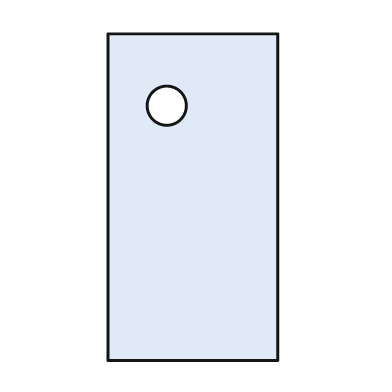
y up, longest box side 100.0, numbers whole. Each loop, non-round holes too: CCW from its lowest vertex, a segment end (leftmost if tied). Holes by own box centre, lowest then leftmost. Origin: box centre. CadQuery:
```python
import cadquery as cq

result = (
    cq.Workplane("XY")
    .moveTo(-26.0, -50.0)
    .lineTo(26.0, -50.0)
    .lineTo(26.0, 50.0)
    .lineTo(-26.0, 50.0)
    .close()
    .moveTo(-8.0, 28.0)
    .circle(6.0)
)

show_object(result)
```